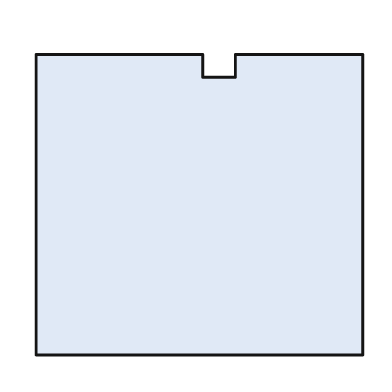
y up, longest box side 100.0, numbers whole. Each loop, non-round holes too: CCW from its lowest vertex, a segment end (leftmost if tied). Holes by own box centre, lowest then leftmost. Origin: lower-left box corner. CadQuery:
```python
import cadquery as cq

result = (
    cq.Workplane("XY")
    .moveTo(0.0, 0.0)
    .lineTo(100.0, 0.0)
    .lineTo(100.0, 92.0)
    .lineTo(61.0, 92.0)
    .lineTo(61.0, 85.0)
    .lineTo(51.0, 85.0)
    .lineTo(51.0, 92.0)
    .lineTo(0.0, 92.0)
    .close()
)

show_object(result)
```